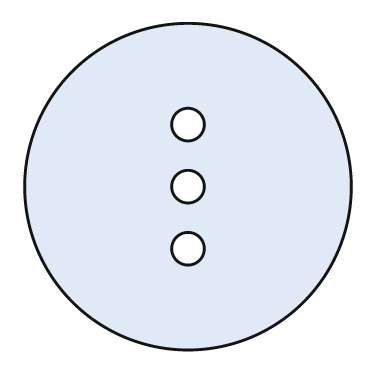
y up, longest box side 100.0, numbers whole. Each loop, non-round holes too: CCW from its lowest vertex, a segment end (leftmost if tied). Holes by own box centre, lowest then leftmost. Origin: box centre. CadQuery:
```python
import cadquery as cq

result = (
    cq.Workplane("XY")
    .moveTo(0.0, 0.0)
    .circle(50.0)
    .moveTo(0.0, -19.0)
    .circle(5.0)
    .moveTo(0.0, 0.0)
    .circle(5.0)
    .moveTo(0.0, 19.0)
    .circle(5.0)
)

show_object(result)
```